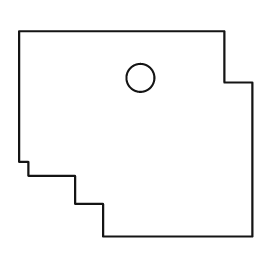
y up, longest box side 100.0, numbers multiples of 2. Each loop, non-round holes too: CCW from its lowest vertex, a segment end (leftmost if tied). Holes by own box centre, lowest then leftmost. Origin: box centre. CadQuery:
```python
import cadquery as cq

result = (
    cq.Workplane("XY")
    .moveTo(-14.0, -44.0)
    .lineTo(50.0, -44.0)
    .lineTo(50.0, 22.0)
    .lineTo(38.0, 22.0)
    .lineTo(38.0, 44.0)
    .lineTo(-50.0, 44.0)
    .lineTo(-50.0, -12.0)
    .lineTo(-46.0, -12.0)
    .lineTo(-46.0, -18.0)
    .lineTo(-26.0, -18.0)
    .lineTo(-26.0, -30.0)
    .lineTo(-14.0, -30.0)
    .close()
    .moveTo(2.0, 24.0)
    .circle(6.0)
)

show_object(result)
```